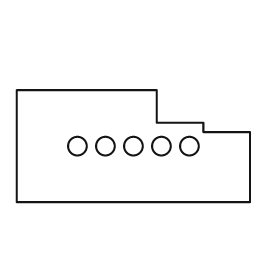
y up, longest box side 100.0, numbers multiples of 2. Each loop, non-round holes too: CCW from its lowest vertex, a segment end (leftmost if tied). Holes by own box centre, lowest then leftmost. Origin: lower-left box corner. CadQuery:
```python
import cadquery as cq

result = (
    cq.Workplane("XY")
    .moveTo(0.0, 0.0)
    .lineTo(100.0, 0.0)
    .lineTo(100.0, 30.0)
    .lineTo(80.0, 30.0)
    .lineTo(80.0, 34.0)
    .lineTo(60.0, 34.0)
    .lineTo(60.0, 48.0)
    .lineTo(0.0, 48.0)
    .close()
    .moveTo(26.0, 24.0)
    .circle(4.0)
    .moveTo(38.0, 24.0)
    .circle(4.0)
    .moveTo(50.0, 24.0)
    .circle(4.0)
    .moveTo(62.0, 24.0)
    .circle(4.0)
    .moveTo(74.0, 24.0)
    .circle(4.0)
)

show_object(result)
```